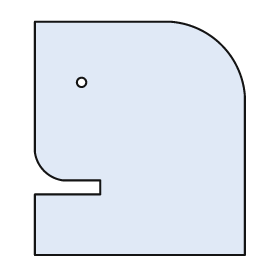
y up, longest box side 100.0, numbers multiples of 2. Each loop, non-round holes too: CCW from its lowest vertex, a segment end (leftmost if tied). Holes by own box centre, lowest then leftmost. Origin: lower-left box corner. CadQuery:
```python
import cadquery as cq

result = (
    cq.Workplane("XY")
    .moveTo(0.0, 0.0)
    .lineTo(90.0, 0.0)
    .lineTo(90.0, 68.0)
    .threePointArc((80.0, 90.0), (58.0, 100.0))
    .lineTo(0.0, 100.0)
    .lineTo(0.0, 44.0)
    .threePointArc((4.0, 36.0), (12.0, 32.0))
    .lineTo(28.0, 32.0)
    .lineTo(28.0, 26.0)
    .lineTo(0.0, 26.0)
    .close()
    .moveTo(20.0, 74.0)
    .circle(2.0)
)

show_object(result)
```